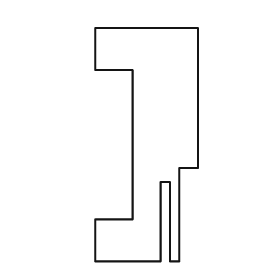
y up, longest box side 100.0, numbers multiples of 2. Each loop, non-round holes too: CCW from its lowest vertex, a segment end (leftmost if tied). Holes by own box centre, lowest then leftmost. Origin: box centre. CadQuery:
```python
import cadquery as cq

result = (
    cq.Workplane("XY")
    .moveTo(-22.0, -50.0)
    .lineTo(6.0, -50.0)
    .lineTo(6.0, -16.0)
    .lineTo(10.0, -16.0)
    .lineTo(10.0, -50.0)
    .lineTo(14.0, -50.0)
    .lineTo(14.0, -10.0)
    .lineTo(22.0, -10.0)
    .lineTo(22.0, 50.0)
    .lineTo(-22.0, 50.0)
    .lineTo(-22.0, 32.0)
    .lineTo(-6.0, 32.0)
    .lineTo(-6.0, -32.0)
    .lineTo(-22.0, -32.0)
    .close()
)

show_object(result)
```